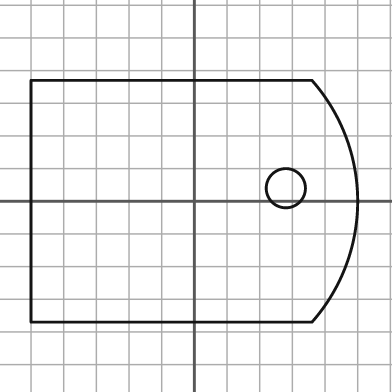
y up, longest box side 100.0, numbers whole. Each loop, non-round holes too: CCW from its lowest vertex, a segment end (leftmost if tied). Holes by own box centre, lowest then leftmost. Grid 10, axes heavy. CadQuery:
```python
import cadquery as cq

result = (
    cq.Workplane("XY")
    .moveTo(-50.0, -37.0)
    .lineTo(36.0, -37.0)
    .threePointArc((50.0, 0.0), (36.0, 37.0))
    .lineTo(-50.0, 37.0)
    .close()
    .moveTo(28.0, 4.0)
    .circle(6.0)
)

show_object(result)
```